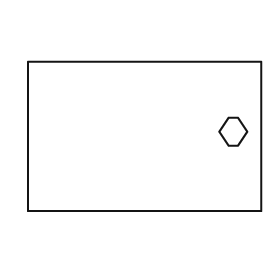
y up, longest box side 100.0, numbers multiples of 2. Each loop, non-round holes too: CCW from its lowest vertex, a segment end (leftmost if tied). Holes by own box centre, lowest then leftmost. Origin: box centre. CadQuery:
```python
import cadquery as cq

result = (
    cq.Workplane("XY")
    .moveTo(-50.0, -32.0)
    .lineTo(50.0, -32.0)
    .lineTo(50.0, 32.0)
    .lineTo(-50.0, 32.0)
    .close()
    .moveTo(36.0, -4.0)
    .lineTo(40.0, -4.0)
    .lineTo(44.0, 2.0)
    .lineTo(40.0, 8.0)
    .lineTo(36.0, 8.0)
    .lineTo(32.0, 2.0)
    .close()
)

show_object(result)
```